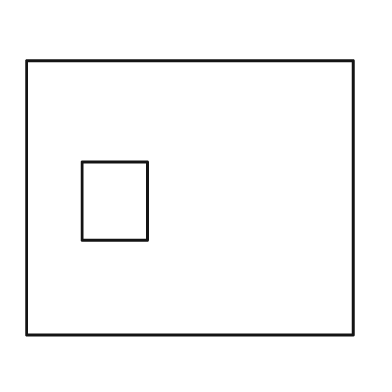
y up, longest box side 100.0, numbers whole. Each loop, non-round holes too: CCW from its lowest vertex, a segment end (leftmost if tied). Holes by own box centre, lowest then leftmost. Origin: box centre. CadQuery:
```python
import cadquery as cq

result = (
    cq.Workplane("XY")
    .moveTo(-50.0, -42.0)
    .lineTo(50.0, -42.0)
    .lineTo(50.0, 42.0)
    .lineTo(-50.0, 42.0)
    .close()
    .moveTo(-33.0, -13.0)
    .lineTo(-13.0, -13.0)
    .lineTo(-13.0, 11.0)
    .lineTo(-33.0, 11.0)
    .close()
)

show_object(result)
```